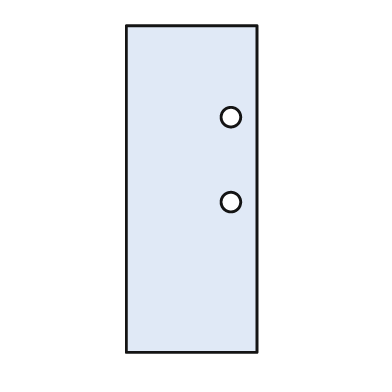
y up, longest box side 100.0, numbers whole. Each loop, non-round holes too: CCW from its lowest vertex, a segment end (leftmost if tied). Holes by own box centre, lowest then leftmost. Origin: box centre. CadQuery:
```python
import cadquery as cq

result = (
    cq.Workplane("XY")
    .moveTo(-20.0, -50.0)
    .lineTo(20.0, -50.0)
    .lineTo(20.0, 50.0)
    .lineTo(-20.0, 50.0)
    .close()
    .moveTo(12.0, -4.0)
    .circle(3.0)
    .moveTo(12.0, 22.0)
    .circle(3.0)
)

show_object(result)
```